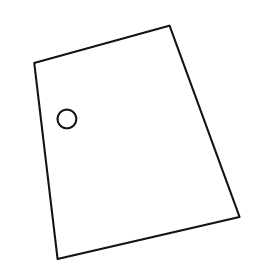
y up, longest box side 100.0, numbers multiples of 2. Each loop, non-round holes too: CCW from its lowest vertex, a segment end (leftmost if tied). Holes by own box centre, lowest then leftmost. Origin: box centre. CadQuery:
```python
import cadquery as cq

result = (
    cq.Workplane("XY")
    .moveTo(-34.0, -50.0)
    .lineTo(44.0, -32.0)
    .lineTo(14.0, 50.0)
    .lineTo(-44.0, 34.0)
    .close()
    .moveTo(-30.0, 10.0)
    .circle(4.0)
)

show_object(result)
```